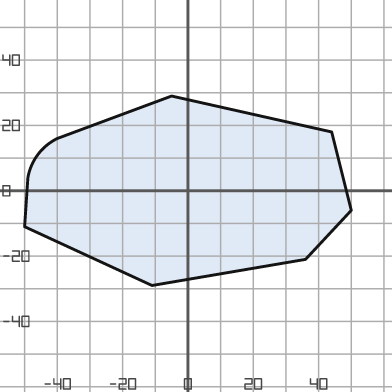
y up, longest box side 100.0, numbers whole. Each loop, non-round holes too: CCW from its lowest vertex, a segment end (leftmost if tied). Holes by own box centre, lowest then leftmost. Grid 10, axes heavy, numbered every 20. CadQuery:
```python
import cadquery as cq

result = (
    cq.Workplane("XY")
    .moveTo(-11.0, -29.0)
    .lineTo(36.0, -21.0)
    .lineTo(50.0, -6.0)
    .lineTo(44.0, 18.0)
    .lineTo(-5.0, 29.0)
    .lineTo(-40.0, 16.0)
    .threePointArc((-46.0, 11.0), (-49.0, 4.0))
    .lineTo(-50.0, -11.0)
    .close()
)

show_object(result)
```